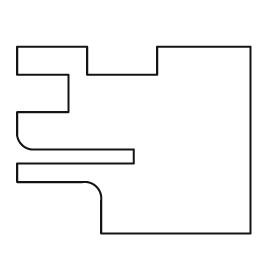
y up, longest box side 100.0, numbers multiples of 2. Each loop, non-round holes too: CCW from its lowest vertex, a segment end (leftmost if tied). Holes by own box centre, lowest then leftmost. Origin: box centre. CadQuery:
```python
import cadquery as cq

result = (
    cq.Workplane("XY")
    .moveTo(-14.0, -40.0)
    .lineTo(50.0, -40.0)
    .lineTo(50.0, 40.0)
    .lineTo(10.0, 40.0)
    .lineTo(10.0, 28.0)
    .lineTo(-20.0, 28.0)
    .lineTo(-20.0, 40.0)
    .lineTo(-50.0, 40.0)
    .lineTo(-50.0, 28.0)
    .lineTo(-28.0, 28.0)
    .lineTo(-28.0, 12.0)
    .lineTo(-50.0, 12.0)
    .lineTo(-50.0, 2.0)
    .threePointArc((-48.0, -2.0), (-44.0, -4.0))
    .lineTo(0.0, -4.0)
    .lineTo(0.0, -10.0)
    .lineTo(-50.0, -10.0)
    .lineTo(-50.0, -18.0)
    .lineTo(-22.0, -18.0)
    .threePointArc((-16.0, -20.0), (-14.0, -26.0))
    .close()
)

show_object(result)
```